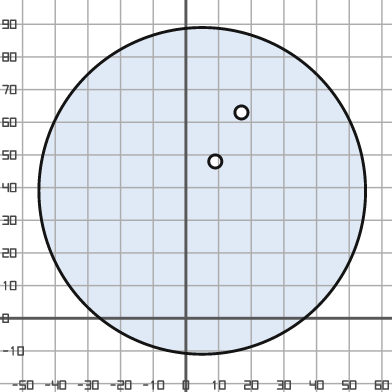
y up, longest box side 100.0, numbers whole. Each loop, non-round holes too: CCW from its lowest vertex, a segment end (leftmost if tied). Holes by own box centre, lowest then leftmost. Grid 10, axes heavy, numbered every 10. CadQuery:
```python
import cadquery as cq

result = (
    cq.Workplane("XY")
    .moveTo(5.0, 39.0)
    .circle(50.0)
    .moveTo(9.0, 48.0)
    .circle(2.0)
    .moveTo(17.0, 63.0)
    .circle(2.0)
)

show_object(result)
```